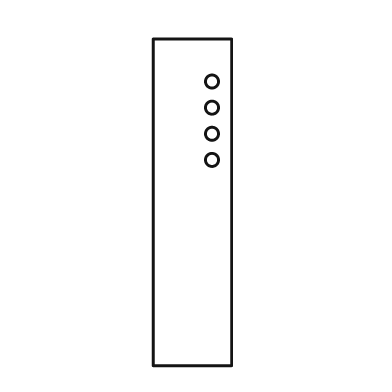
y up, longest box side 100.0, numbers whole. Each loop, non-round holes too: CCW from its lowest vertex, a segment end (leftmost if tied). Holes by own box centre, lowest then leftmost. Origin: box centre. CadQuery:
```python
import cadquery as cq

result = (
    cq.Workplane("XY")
    .moveTo(-12.0, -50.0)
    .lineTo(12.0, -50.0)
    .lineTo(12.0, 50.0)
    .lineTo(-12.0, 50.0)
    .close()
    .moveTo(6.0, 13.0)
    .circle(2.0)
    .moveTo(6.0, 21.0)
    .circle(2.0)
    .moveTo(6.0, 29.0)
    .circle(2.0)
    .moveTo(6.0, 37.0)
    .circle(2.0)
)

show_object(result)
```